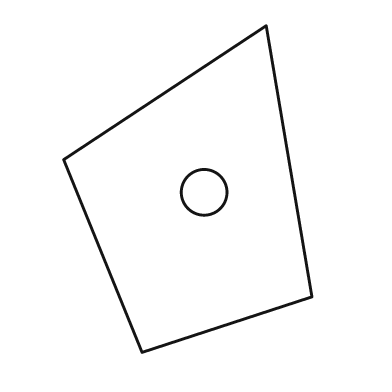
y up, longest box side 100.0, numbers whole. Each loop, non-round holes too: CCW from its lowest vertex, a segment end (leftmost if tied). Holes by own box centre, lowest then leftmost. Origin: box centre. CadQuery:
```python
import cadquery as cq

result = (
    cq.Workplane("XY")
    .moveTo(-14.0, -50.0)
    .lineTo(38.0, -33.0)
    .lineTo(24.0, 50.0)
    .lineTo(-38.0, 9.0)
    .close()
    .moveTo(5.0, -1.0)
    .circle(7.0)
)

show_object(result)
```